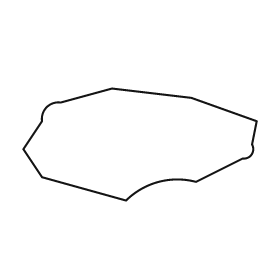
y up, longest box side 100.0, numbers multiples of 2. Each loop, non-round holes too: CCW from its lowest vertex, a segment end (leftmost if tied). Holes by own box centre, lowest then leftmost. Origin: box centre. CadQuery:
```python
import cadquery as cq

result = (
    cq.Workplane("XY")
    .moveTo(-6.0, -24.0)
    .threePointArc((8.0, -16.0), (24.0, -16.0))
    .lineTo(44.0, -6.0)
    .threePointArc((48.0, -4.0), (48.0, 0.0))
    .lineTo(50.0, 10.0)
    .lineTo(22.0, 20.0)
    .lineTo(-12.0, 24.0)
    .lineTo(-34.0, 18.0)
    .threePointArc((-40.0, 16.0), (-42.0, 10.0))
    .lineTo(-50.0, -2.0)
    .lineTo(-42.0, -14.0)
    .close()
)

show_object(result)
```